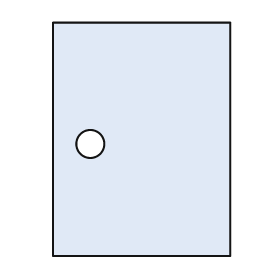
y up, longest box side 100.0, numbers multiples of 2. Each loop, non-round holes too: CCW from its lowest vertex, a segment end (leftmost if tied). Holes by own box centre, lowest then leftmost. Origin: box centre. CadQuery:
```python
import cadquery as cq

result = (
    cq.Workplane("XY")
    .moveTo(-38.0, -50.0)
    .lineTo(38.0, -50.0)
    .lineTo(38.0, 50.0)
    .lineTo(-38.0, 50.0)
    .close()
    .moveTo(-22.0, -2.0)
    .circle(6.0)
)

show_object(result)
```